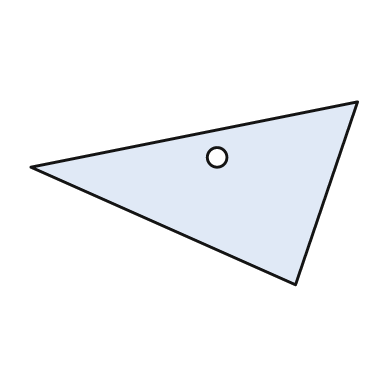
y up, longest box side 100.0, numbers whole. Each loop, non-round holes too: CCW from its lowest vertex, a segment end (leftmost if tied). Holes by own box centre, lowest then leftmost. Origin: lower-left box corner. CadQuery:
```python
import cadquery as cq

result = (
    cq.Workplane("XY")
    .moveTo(81.0, 0.0)
    .lineTo(100.0, 56.0)
    .lineTo(0.0, 36.0)
    .close()
    .moveTo(57.0, 39.0)
    .circle(3.0)
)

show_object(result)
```